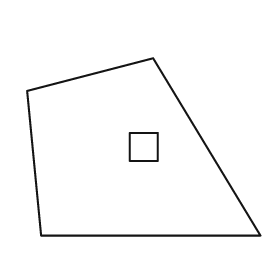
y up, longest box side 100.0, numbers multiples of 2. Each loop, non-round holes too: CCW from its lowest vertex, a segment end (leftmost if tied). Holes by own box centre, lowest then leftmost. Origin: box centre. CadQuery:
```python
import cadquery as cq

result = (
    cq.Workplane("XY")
    .moveTo(-44.0, -38.0)
    .lineTo(50.0, -38.0)
    .lineTo(4.0, 38.0)
    .lineTo(-50.0, 24.0)
    .close()
    .moveTo(-6.0, -6.0)
    .lineTo(6.0, -6.0)
    .lineTo(6.0, 6.0)
    .lineTo(-6.0, 6.0)
    .close()
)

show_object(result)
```